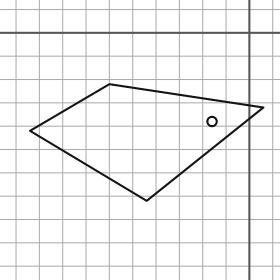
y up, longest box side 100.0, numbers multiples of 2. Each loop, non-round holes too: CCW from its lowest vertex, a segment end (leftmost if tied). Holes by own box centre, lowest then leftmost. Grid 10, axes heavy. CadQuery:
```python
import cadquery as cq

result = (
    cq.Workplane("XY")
    .moveTo(-44.0, -72.0)
    .lineTo(6.0, -32.0)
    .lineTo(-60.0, -22.0)
    .lineTo(-94.0, -42.0)
    .close()
    .moveTo(-16.0, -38.0)
    .circle(2.0)
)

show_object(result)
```